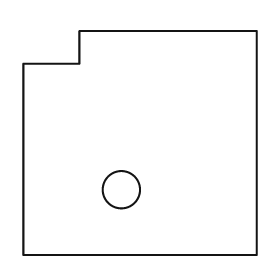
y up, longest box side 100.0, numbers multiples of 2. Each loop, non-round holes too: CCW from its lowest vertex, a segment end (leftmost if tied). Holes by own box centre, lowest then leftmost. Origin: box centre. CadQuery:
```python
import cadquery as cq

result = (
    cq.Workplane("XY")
    .moveTo(-50.0, -48.0)
    .lineTo(50.0, -48.0)
    .lineTo(50.0, 48.0)
    .lineTo(-26.0, 48.0)
    .lineTo(-26.0, 34.0)
    .lineTo(-50.0, 34.0)
    .close()
    .moveTo(-8.0, -20.0)
    .circle(8.0)
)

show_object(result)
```